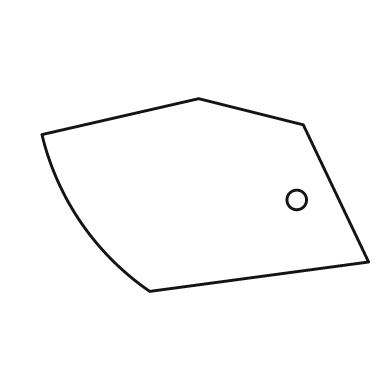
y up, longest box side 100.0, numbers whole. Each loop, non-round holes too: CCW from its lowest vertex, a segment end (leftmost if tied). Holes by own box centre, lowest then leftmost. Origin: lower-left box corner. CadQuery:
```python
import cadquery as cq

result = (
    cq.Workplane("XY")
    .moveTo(33.0, 0.0)
    .lineTo(100.0, 9.0)
    .lineTo(80.0, 51.0)
    .lineTo(48.0, 59.0)
    .lineTo(0.0, 48.0)
    .threePointArc((12.0, 21.0), (33.0, 0.0))
    .close()
    .moveTo(78.0, 28.0)
    .circle(3.0)
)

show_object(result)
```